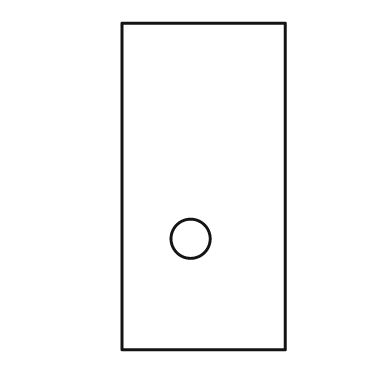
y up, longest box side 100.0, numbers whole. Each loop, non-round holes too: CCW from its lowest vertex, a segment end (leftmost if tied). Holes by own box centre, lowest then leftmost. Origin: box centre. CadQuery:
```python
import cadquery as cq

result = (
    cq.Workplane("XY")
    .moveTo(-25.0, -50.0)
    .lineTo(25.0, -50.0)
    .lineTo(25.0, 50.0)
    .lineTo(-25.0, 50.0)
    .close()
    .moveTo(-4.0, -16.0)
    .circle(6.0)
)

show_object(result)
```